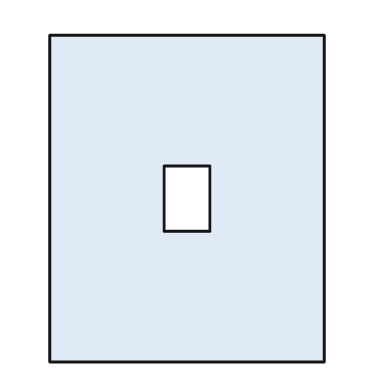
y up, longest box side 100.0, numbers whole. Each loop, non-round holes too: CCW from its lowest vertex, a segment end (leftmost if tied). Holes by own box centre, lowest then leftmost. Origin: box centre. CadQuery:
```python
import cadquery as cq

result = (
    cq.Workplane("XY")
    .moveTo(-42.0, -50.0)
    .lineTo(42.0, -50.0)
    .lineTo(42.0, 50.0)
    .lineTo(-42.0, 50.0)
    .close()
    .moveTo(-7.0, -10.0)
    .lineTo(7.0, -10.0)
    .lineTo(7.0, 10.0)
    .lineTo(-7.0, 10.0)
    .close()
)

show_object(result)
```